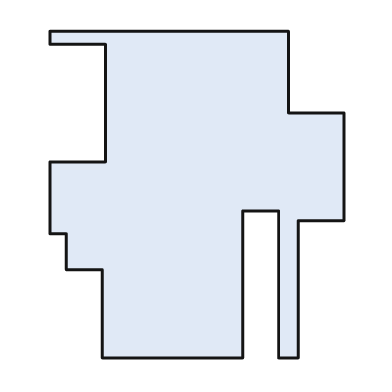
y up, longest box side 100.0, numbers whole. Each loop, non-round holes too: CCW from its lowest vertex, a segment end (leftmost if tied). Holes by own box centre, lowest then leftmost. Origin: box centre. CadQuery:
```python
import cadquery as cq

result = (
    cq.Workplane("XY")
    .moveTo(-29.0, -50.0)
    .lineTo(14.0, -50.0)
    .lineTo(14.0, -5.0)
    .lineTo(25.0, -5.0)
    .lineTo(25.0, -50.0)
    .lineTo(31.0, -50.0)
    .lineTo(31.0, -8.0)
    .lineTo(45.0, -8.0)
    .lineTo(45.0, 25.0)
    .lineTo(28.0, 25.0)
    .lineTo(28.0, 50.0)
    .lineTo(-45.0, 50.0)
    .lineTo(-45.0, 46.0)
    .lineTo(-28.0, 46.0)
    .lineTo(-28.0, 10.0)
    .lineTo(-45.0, 10.0)
    .lineTo(-45.0, -12.0)
    .lineTo(-40.0, -12.0)
    .lineTo(-40.0, -23.0)
    .lineTo(-29.0, -23.0)
    .close()
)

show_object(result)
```